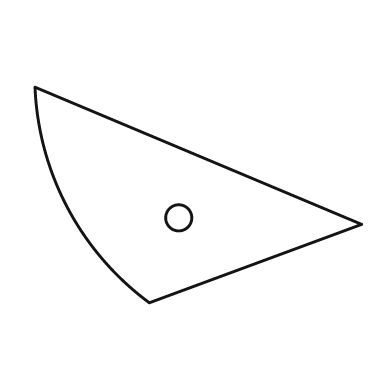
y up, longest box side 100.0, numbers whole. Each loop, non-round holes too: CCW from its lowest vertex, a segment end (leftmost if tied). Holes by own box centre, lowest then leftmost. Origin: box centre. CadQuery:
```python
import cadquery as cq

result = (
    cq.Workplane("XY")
    .moveTo(-15.0, -33.0)
    .lineTo(50.0, -9.0)
    .lineTo(-50.0, 33.0)
    .threePointArc((-40.0, -4.0), (-15.0, -33.0))
    .close()
    .moveTo(-6.0, -7.0)
    .circle(4.0)
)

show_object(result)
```